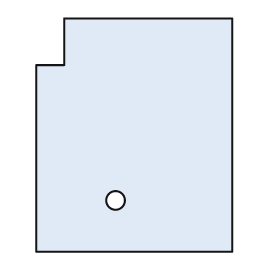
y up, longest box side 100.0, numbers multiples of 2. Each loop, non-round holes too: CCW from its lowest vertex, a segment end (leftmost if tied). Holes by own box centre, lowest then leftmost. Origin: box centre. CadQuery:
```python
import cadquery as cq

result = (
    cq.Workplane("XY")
    .moveTo(-42.0, -50.0)
    .lineTo(42.0, -50.0)
    .lineTo(42.0, 50.0)
    .lineTo(-30.0, 50.0)
    .lineTo(-30.0, 30.0)
    .lineTo(-42.0, 30.0)
    .close()
    .moveTo(-8.0, -28.0)
    .circle(4.0)
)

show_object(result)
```